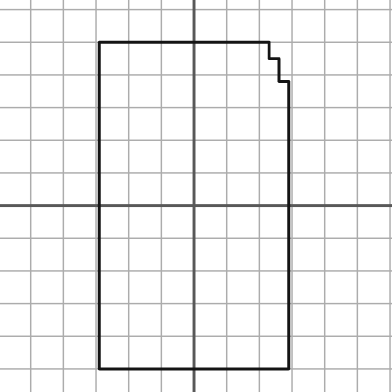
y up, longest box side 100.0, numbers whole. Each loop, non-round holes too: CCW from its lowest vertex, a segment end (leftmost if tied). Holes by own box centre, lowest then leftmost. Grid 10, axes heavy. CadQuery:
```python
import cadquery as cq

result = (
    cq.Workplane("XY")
    .moveTo(-29.0, -50.0)
    .lineTo(29.0, -50.0)
    .lineTo(29.0, 38.0)
    .lineTo(26.0, 38.0)
    .lineTo(26.0, 45.0)
    .lineTo(23.0, 45.0)
    .lineTo(23.0, 50.0)
    .lineTo(-29.0, 50.0)
    .close()
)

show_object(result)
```